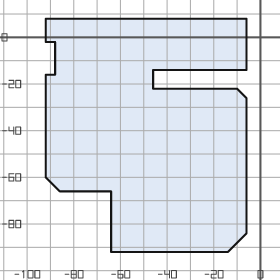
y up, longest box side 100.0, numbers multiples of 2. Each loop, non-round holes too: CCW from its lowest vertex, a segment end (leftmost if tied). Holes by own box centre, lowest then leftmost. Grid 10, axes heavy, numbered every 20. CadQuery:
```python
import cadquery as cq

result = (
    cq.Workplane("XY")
    .moveTo(-64.0, -92.0)
    .lineTo(-14.0, -92.0)
    .lineTo(-6.0, -84.0)
    .lineTo(-6.0, -26.0)
    .lineTo(-10.0, -22.0)
    .lineTo(-46.0, -22.0)
    .lineTo(-46.0, -14.0)
    .lineTo(-6.0, -14.0)
    .lineTo(-6.0, 8.0)
    .lineTo(-92.0, 8.0)
    .lineTo(-92.0, -2.0)
    .lineTo(-88.0, -2.0)
    .lineTo(-88.0, -16.0)
    .lineTo(-92.0, -16.0)
    .lineTo(-92.0, -60.0)
    .lineTo(-86.0, -66.0)
    .lineTo(-64.0, -66.0)
    .close()
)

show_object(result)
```